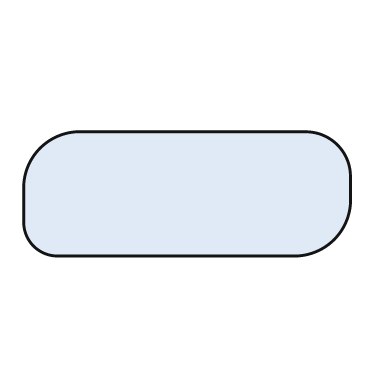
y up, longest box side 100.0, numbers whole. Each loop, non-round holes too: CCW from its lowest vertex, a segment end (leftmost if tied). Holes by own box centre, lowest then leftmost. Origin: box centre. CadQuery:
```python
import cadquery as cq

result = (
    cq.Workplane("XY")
    .moveTo(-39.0, -19.0)
    .lineTo(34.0, -19.0)
    .threePointArc((45.0, -14.0), (50.0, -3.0))
    .lineTo(50.0, 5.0)
    .threePointArc((46.0, 15.0), (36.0, 19.0))
    .lineTo(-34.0, 19.0)
    .threePointArc((-45.0, 14.0), (-50.0, 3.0))
    .lineTo(-50.0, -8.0)
    .threePointArc((-47.0, -16.0), (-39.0, -19.0))
    .close()
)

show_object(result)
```